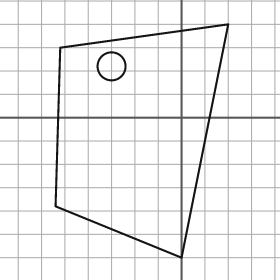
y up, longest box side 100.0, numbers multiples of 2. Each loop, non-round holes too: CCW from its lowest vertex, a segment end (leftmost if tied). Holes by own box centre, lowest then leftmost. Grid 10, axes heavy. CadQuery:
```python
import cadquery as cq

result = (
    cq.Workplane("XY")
    .moveTo(0.0, -60.0)
    .lineTo(20.0, 40.0)
    .lineTo(-52.0, 30.0)
    .lineTo(-54.0, -38.0)
    .close()
    .moveTo(-30.0, 22.0)
    .circle(6.0)
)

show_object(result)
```